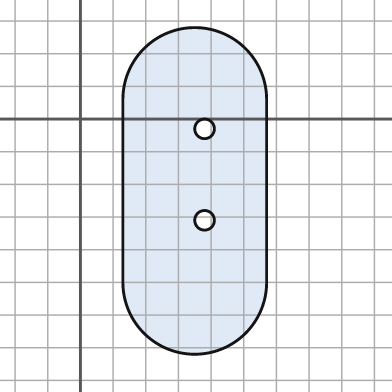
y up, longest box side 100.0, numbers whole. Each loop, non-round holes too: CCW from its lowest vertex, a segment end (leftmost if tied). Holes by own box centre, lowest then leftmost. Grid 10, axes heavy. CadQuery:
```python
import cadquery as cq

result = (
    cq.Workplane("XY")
    .moveTo(13.0, -50.0)
    .threePointArc((35.0, -72.0), (57.0, -50.0))
    .lineTo(57.0, 6.0)
    .threePointArc((35.0, 28.0), (13.0, 6.0))
    .close()
    .moveTo(38.0, -31.0)
    .circle(3.0)
    .moveTo(38.0, -3.0)
    .circle(3.0)
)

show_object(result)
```